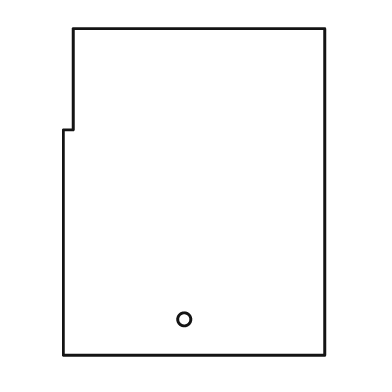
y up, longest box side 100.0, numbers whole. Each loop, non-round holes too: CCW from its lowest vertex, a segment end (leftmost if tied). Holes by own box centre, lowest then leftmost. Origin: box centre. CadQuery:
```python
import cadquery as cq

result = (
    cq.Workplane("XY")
    .moveTo(-40.0, -50.0)
    .lineTo(40.0, -50.0)
    .lineTo(40.0, 50.0)
    .lineTo(-37.0, 50.0)
    .lineTo(-37.0, 19.0)
    .lineTo(-40.0, 19.0)
    .close()
    .moveTo(-3.0, -39.0)
    .circle(2.0)
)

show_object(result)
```